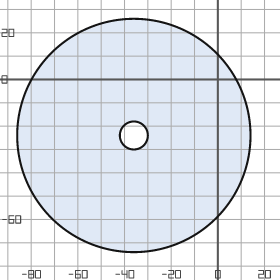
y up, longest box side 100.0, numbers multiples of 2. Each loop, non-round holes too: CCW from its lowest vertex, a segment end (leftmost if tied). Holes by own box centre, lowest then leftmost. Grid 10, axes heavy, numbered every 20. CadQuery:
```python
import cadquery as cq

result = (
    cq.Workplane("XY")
    .moveTo(-36.0, -24.0)
    .circle(50.0)
    .moveTo(-36.0, -24.0)
    .circle(6.0)
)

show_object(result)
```